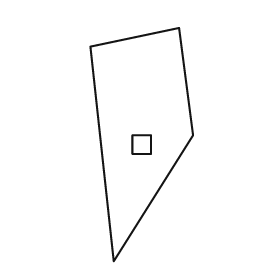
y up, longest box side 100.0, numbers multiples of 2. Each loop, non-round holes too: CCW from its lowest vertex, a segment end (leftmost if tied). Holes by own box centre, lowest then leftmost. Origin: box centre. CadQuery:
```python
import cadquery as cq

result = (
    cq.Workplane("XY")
    .moveTo(-12.0, -50.0)
    .lineTo(22.0, 4.0)
    .lineTo(16.0, 50.0)
    .lineTo(-22.0, 42.0)
    .close()
    .moveTo(-4.0, -4.0)
    .lineTo(4.0, -4.0)
    .lineTo(4.0, 4.0)
    .lineTo(-4.0, 4.0)
    .close()
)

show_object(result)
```